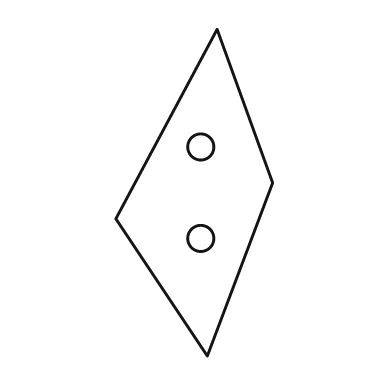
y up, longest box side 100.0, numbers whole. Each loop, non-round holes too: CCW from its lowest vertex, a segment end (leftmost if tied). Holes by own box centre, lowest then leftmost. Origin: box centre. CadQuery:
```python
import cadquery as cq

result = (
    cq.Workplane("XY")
    .moveTo(4.0, -50.0)
    .lineTo(24.0, 3.0)
    .lineTo(7.0, 50.0)
    .lineTo(-24.0, -8.0)
    .close()
    .moveTo(2.0, -14.0)
    .circle(4.0)
    .moveTo(2.0, 14.0)
    .circle(4.0)
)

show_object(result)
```